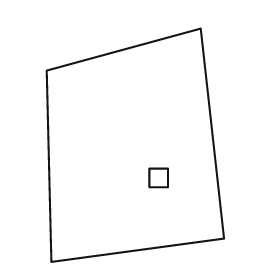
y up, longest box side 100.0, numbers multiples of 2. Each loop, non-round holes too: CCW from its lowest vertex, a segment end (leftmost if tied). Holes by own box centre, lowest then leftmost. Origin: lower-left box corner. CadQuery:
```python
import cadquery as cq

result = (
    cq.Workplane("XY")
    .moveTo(2.0, 0.0)
    .lineTo(76.0, 10.0)
    .lineTo(66.0, 100.0)
    .lineTo(0.0, 82.0)
    .close()
    .moveTo(44.0, 32.0)
    .lineTo(52.0, 32.0)
    .lineTo(52.0, 40.0)
    .lineTo(44.0, 40.0)
    .close()
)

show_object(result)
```